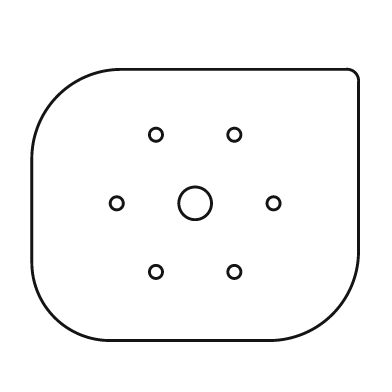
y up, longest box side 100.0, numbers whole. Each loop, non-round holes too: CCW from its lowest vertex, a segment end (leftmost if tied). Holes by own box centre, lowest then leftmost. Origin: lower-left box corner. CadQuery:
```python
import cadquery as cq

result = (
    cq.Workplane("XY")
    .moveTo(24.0, 0.0)
    .lineTo(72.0, 0.0)
    .threePointArc((92.0, 8.0), (100.0, 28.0))
    .lineTo(100.0, 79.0)
    .threePointArc((99.0, 82.0), (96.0, 83.0))
    .lineTo(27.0, 83.0)
    .threePointArc((8.0, 75.0), (0.0, 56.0))
    .lineTo(0.0, 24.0)
    .threePointArc((7.0, 7.0), (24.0, 0.0))
    .close()
    .moveTo(38.0, 21.0)
    .circle(2.0)
    .moveTo(62.0, 21.0)
    .circle(2.0)
    .moveTo(26.0, 42.0)
    .circle(2.0)
    .moveTo(50.0, 42.0)
    .circle(5.0)
    .moveTo(74.0, 42.0)
    .circle(2.0)
    .moveTo(38.0, 63.0)
    .circle(2.0)
    .moveTo(62.0, 63.0)
    .circle(2.0)
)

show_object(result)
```